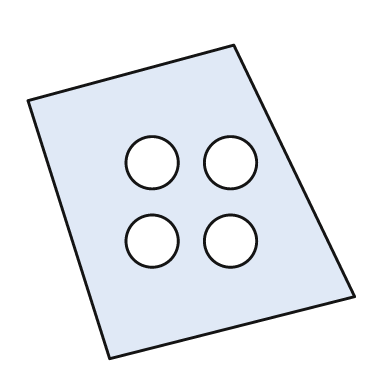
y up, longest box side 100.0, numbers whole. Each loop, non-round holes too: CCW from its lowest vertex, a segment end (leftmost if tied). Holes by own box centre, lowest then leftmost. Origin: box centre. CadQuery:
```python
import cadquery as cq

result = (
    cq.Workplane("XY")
    .moveTo(-25.0, -48.0)
    .lineTo(50.0, -29.0)
    .lineTo(13.0, 48.0)
    .lineTo(-50.0, 31.0)
    .close()
    .moveTo(-12.0, -12.0)
    .circle(8.0)
    .moveTo(12.0, -12.0)
    .circle(8.0)
    .moveTo(-12.0, 12.0)
    .circle(8.0)
    .moveTo(12.0, 12.0)
    .circle(8.0)
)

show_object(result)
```